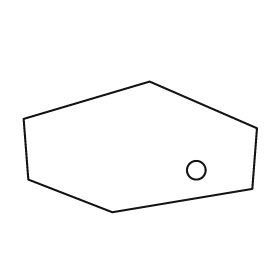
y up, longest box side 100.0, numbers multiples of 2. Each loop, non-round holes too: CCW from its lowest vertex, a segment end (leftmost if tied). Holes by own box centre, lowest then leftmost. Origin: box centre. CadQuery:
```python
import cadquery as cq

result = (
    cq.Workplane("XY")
    .moveTo(-12.0, -28.0)
    .lineTo(48.0, -18.0)
    .lineTo(50.0, 8.0)
    .lineTo(4.0, 28.0)
    .lineTo(-50.0, 12.0)
    .lineTo(-48.0, -14.0)
    .close()
    .moveTo(24.0, -10.0)
    .circle(4.0)
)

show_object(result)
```